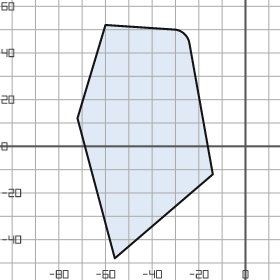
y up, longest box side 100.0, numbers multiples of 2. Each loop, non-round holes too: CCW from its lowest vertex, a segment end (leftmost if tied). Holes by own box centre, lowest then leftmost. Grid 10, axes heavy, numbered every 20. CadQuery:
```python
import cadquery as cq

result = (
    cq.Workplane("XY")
    .moveTo(-56.0, -48.0)
    .lineTo(-14.0, -12.0)
    .lineTo(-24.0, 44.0)
    .threePointArc((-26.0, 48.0), (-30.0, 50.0))
    .lineTo(-60.0, 52.0)
    .lineTo(-72.0, 12.0)
    .close()
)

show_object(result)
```